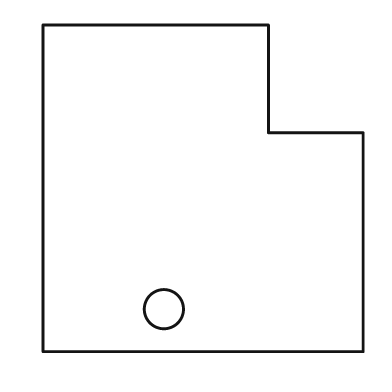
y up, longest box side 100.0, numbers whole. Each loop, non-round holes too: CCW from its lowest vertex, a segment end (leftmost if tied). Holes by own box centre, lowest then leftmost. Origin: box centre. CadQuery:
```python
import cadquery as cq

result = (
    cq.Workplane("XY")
    .moveTo(-49.0, -50.0)
    .lineTo(49.0, -50.0)
    .lineTo(49.0, 17.0)
    .lineTo(20.0, 17.0)
    .lineTo(20.0, 50.0)
    .lineTo(-49.0, 50.0)
    .close()
    .moveTo(-12.0, -37.0)
    .circle(6.0)
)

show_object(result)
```